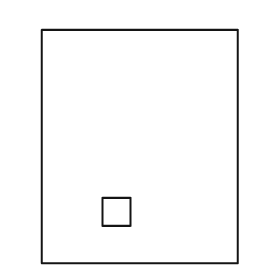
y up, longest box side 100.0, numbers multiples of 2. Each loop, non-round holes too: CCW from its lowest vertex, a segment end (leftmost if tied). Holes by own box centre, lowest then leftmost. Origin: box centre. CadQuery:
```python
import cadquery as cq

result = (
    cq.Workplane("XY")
    .moveTo(-42.0, -50.0)
    .lineTo(42.0, -50.0)
    .lineTo(42.0, 50.0)
    .lineTo(-42.0, 50.0)
    .close()
    .moveTo(-16.0, -34.0)
    .lineTo(-4.0, -34.0)
    .lineTo(-4.0, -22.0)
    .lineTo(-16.0, -22.0)
    .close()
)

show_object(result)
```